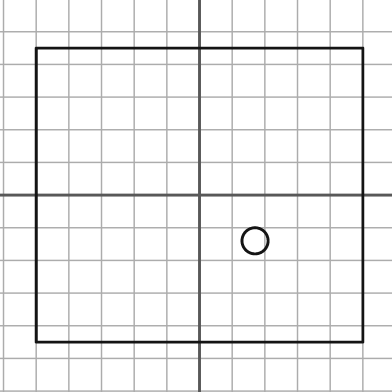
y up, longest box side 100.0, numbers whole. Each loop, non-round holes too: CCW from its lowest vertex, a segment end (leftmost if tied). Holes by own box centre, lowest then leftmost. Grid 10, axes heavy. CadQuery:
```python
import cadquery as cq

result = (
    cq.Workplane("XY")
    .moveTo(-50.0, -45.0)
    .lineTo(50.0, -45.0)
    .lineTo(50.0, 45.0)
    .lineTo(-50.0, 45.0)
    .close()
    .moveTo(17.0, -14.0)
    .circle(4.0)
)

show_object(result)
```